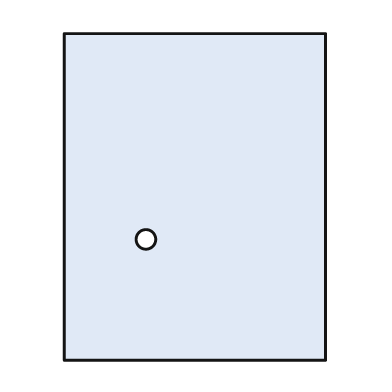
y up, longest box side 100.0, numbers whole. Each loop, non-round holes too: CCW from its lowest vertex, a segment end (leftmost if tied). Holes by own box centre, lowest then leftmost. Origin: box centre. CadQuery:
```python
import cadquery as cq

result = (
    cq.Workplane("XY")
    .moveTo(-40.0, -50.0)
    .lineTo(40.0, -50.0)
    .lineTo(40.0, 50.0)
    .lineTo(-40.0, 50.0)
    .close()
    .moveTo(-15.0, -13.0)
    .circle(3.0)
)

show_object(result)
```